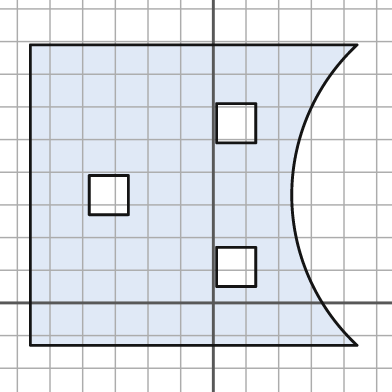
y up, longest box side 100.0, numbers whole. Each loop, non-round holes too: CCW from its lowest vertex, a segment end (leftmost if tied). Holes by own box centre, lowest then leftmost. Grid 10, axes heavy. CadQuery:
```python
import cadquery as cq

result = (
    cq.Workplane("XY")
    .moveTo(-56.0, -13.0)
    .lineTo(44.0, -13.0)
    .threePointArc((24.0, 33.0), (44.0, 79.0))
    .lineTo(-56.0, 79.0)
    .close()
    .moveTo(1.0, 5.0)
    .lineTo(13.0, 5.0)
    .lineTo(13.0, 17.0)
    .lineTo(1.0, 17.0)
    .close()
    .moveTo(-38.0, 27.0)
    .lineTo(-26.0, 27.0)
    .lineTo(-26.0, 39.0)
    .lineTo(-38.0, 39.0)
    .close()
    .moveTo(1.0, 49.0)
    .lineTo(13.0, 49.0)
    .lineTo(13.0, 61.0)
    .lineTo(1.0, 61.0)
    .close()
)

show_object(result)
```